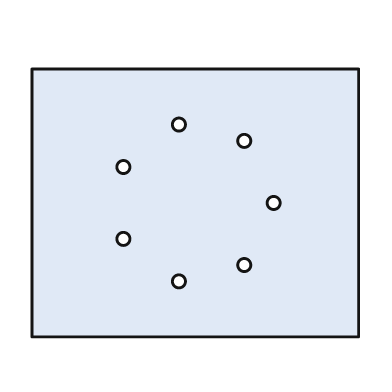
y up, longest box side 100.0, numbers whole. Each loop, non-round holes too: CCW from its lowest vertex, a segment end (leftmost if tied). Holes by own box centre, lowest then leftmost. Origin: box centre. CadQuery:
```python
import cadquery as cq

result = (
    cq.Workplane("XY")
    .moveTo(-50.0, -41.0)
    .lineTo(50.0, -41.0)
    .lineTo(50.0, 41.0)
    .lineTo(-50.0, 41.0)
    .close()
    .moveTo(-5.0, -24.0)
    .circle(2.0)
    .moveTo(15.0, -19.0)
    .circle(2.0)
    .moveTo(-22.0, -11.0)
    .circle(2.0)
    .moveTo(24.0, 0.0)
    .circle(2.0)
    .moveTo(-22.0, 11.0)
    .circle(2.0)
    .moveTo(15.0, 19.0)
    .circle(2.0)
    .moveTo(-5.0, 24.0)
    .circle(2.0)
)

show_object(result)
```